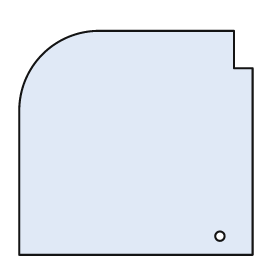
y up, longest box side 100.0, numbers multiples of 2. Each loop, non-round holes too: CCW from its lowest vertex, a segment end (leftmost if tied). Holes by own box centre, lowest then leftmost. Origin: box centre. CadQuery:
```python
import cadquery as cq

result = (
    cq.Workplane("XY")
    .moveTo(-50.0, -48.0)
    .lineTo(50.0, -48.0)
    .lineTo(50.0, 32.0)
    .lineTo(42.0, 32.0)
    .lineTo(42.0, 48.0)
    .lineTo(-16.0, 48.0)
    .threePointArc((-40.0, 38.0), (-50.0, 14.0))
    .close()
    .moveTo(36.0, -40.0)
    .circle(2.0)
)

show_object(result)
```